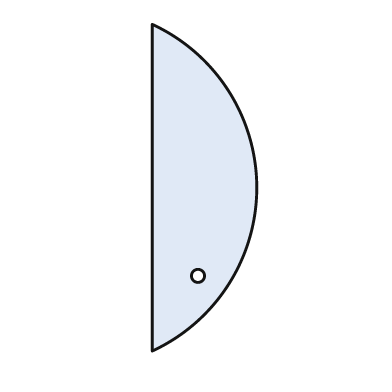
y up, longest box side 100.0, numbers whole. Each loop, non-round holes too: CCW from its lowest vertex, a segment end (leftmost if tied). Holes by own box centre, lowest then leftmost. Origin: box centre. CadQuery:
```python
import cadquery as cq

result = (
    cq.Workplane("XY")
    .moveTo(-16.0, -50.0)
    .threePointArc((16.0, 0.0), (-16.0, 50.0))
    .close()
    .moveTo(-2.0, -27.0)
    .circle(2.0)
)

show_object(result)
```